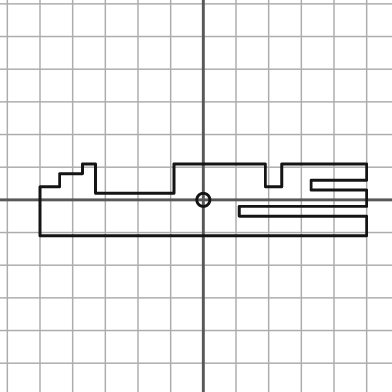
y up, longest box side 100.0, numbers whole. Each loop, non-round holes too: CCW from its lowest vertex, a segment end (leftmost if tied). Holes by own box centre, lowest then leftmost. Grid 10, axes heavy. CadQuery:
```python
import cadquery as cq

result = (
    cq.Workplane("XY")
    .moveTo(-50.0, -11.0)
    .lineTo(50.0, -11.0)
    .lineTo(50.0, -5.0)
    .lineTo(11.0, -5.0)
    .lineTo(11.0, -2.0)
    .lineTo(50.0, -2.0)
    .lineTo(50.0, 3.0)
    .lineTo(33.0, 3.0)
    .lineTo(33.0, 6.0)
    .lineTo(50.0, 6.0)
    .lineTo(50.0, 11.0)
    .lineTo(24.0, 11.0)
    .lineTo(24.0, 4.0)
    .lineTo(19.0, 4.0)
    .lineTo(19.0, 11.0)
    .lineTo(-9.0, 11.0)
    .lineTo(-9.0, 2.0)
    .lineTo(-33.0, 2.0)
    .lineTo(-33.0, 11.0)
    .lineTo(-37.0, 11.0)
    .lineTo(-37.0, 8.0)
    .lineTo(-44.0, 8.0)
    .lineTo(-44.0, 4.0)
    .lineTo(-50.0, 4.0)
    .close()
    .moveTo(0.0, 0.0)
    .circle(2.0)
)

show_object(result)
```